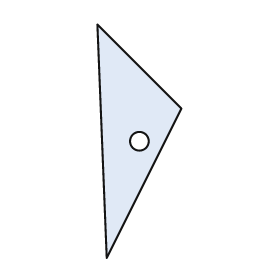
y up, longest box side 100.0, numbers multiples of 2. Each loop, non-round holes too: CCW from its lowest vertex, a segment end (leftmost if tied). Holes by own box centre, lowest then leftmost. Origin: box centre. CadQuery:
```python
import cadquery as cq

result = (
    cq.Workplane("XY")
    .moveTo(-14.0, -50.0)
    .lineTo(18.0, 14.0)
    .lineTo(-18.0, 50.0)
    .close()
    .moveTo(0.0, 0.0)
    .circle(4.0)
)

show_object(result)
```